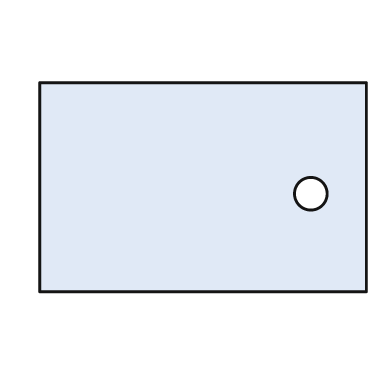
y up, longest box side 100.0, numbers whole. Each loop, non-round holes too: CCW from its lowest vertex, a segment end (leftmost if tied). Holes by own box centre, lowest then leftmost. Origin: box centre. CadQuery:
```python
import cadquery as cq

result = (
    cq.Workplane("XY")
    .moveTo(-50.0, -32.0)
    .lineTo(50.0, -32.0)
    .lineTo(50.0, 32.0)
    .lineTo(-50.0, 32.0)
    .close()
    .moveTo(33.0, -2.0)
    .circle(5.0)
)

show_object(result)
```